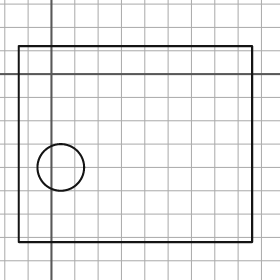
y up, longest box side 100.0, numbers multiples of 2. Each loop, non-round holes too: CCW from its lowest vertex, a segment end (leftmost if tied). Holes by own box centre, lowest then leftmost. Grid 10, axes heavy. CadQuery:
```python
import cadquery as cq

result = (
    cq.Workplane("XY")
    .moveTo(-14.0, -72.0)
    .lineTo(86.0, -72.0)
    .lineTo(86.0, 12.0)
    .lineTo(-14.0, 12.0)
    .close()
    .moveTo(4.0, -40.0)
    .circle(10.0)
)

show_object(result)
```